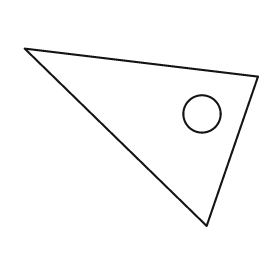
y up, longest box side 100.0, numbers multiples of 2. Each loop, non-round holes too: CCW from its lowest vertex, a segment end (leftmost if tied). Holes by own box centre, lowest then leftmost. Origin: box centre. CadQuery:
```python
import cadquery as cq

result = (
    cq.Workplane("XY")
    .moveTo(28.0, -38.0)
    .lineTo(50.0, 26.0)
    .lineTo(-50.0, 38.0)
    .close()
    .moveTo(26.0, 10.0)
    .circle(8.0)
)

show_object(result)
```